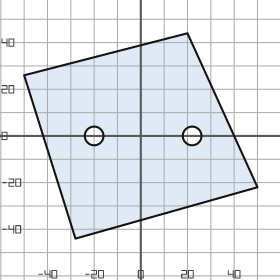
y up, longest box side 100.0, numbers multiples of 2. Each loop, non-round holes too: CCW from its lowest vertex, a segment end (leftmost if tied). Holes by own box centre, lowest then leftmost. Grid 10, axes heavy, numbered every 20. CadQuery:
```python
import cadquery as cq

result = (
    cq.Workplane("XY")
    .moveTo(-28.0, -44.0)
    .lineTo(50.0, -22.0)
    .lineTo(20.0, 44.0)
    .lineTo(-50.0, 26.0)
    .close()
    .moveTo(-20.0, 0.0)
    .circle(4.0)
    .moveTo(22.0, 0.0)
    .circle(4.0)
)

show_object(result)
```